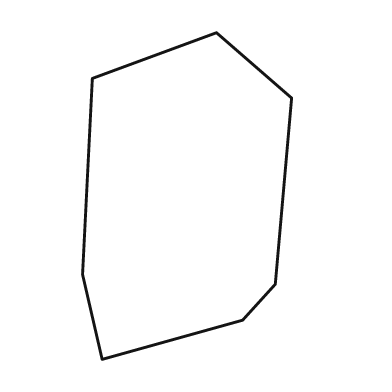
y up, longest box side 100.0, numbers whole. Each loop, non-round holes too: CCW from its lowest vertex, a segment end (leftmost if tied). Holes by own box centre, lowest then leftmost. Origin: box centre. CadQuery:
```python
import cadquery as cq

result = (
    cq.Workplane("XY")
    .moveTo(-26.0, -50.0)
    .lineTo(17.0, -38.0)
    .lineTo(27.0, -27.0)
    .lineTo(32.0, 30.0)
    .lineTo(9.0, 50.0)
    .lineTo(-29.0, 36.0)
    .lineTo(-32.0, -24.0)
    .close()
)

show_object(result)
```